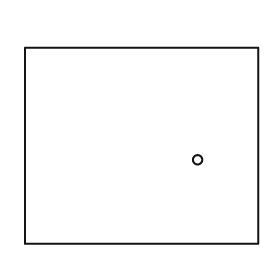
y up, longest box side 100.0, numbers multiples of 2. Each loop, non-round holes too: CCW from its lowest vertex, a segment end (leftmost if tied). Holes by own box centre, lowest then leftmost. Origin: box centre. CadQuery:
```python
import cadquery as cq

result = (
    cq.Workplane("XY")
    .moveTo(-50.0, -42.0)
    .lineTo(50.0, -42.0)
    .lineTo(50.0, 42.0)
    .lineTo(-50.0, 42.0)
    .close()
    .moveTo(24.0, -6.0)
    .circle(2.0)
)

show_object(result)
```